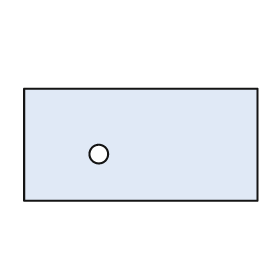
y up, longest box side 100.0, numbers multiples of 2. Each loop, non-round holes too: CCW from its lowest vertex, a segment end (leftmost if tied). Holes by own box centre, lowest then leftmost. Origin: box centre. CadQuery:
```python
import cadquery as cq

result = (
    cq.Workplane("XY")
    .moveTo(-50.0, -24.0)
    .lineTo(50.0, -24.0)
    .lineTo(50.0, 24.0)
    .lineTo(-50.0, 24.0)
    .close()
    .moveTo(-18.0, -4.0)
    .circle(4.0)
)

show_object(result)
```